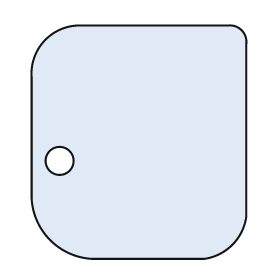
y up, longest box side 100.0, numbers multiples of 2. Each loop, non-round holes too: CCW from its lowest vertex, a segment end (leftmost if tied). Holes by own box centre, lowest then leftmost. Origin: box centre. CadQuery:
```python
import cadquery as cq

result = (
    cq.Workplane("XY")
    .moveTo(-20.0, -50.0)
    .lineTo(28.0, -50.0)
    .threePointArc((40.0, -44.0), (46.0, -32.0))
    .lineTo(46.0, 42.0)
    .threePointArc((44.0, 48.0), (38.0, 50.0))
    .lineTo(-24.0, 50.0)
    .threePointArc((-40.0, 44.0), (-46.0, 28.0))
    .lineTo(-46.0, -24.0)
    .threePointArc((-38.0, -42.0), (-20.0, -50.0))
    .close()
    .moveTo(-34.0, -8.0)
    .circle(6.0)
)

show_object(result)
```